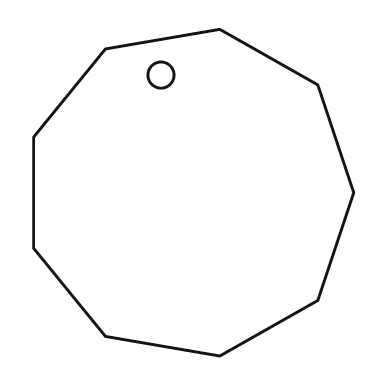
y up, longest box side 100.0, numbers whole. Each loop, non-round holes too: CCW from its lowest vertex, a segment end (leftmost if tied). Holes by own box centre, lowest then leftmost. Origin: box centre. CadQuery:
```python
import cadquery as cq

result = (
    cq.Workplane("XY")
    .moveTo(8.0, -50.0)
    .lineTo(38.0, -33.0)
    .lineTo(49.0, 0.0)
    .lineTo(38.0, 33.0)
    .lineTo(8.0, 50.0)
    .lineTo(-27.0, 44.0)
    .lineTo(-49.0, 17.0)
    .lineTo(-49.0, -17.0)
    .lineTo(-27.0, -44.0)
    .close()
    .moveTo(-10.0, 36.0)
    .circle(4.0)
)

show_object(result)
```